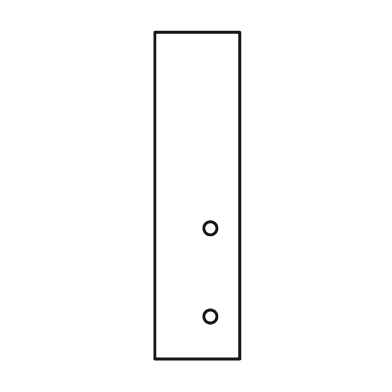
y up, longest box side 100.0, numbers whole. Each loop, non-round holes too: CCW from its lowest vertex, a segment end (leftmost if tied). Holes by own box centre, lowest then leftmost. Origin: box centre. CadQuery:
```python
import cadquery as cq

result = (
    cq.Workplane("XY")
    .moveTo(-13.0, -50.0)
    .lineTo(13.0, -50.0)
    .lineTo(13.0, 50.0)
    .lineTo(-13.0, 50.0)
    .close()
    .moveTo(4.0, -37.0)
    .circle(2.0)
    .moveTo(4.0, -10.0)
    .circle(2.0)
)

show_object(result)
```